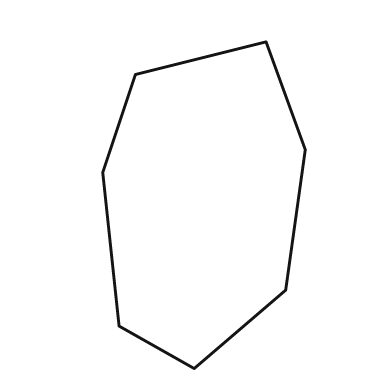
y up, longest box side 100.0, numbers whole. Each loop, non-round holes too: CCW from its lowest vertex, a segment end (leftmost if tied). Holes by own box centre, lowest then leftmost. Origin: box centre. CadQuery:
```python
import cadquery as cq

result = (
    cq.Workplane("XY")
    .moveTo(-3.0, -50.0)
    .lineTo(25.0, -26.0)
    .lineTo(31.0, 17.0)
    .lineTo(19.0, 50.0)
    .lineTo(-21.0, 40.0)
    .lineTo(-31.0, 10.0)
    .lineTo(-26.0, -37.0)
    .close()
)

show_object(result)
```